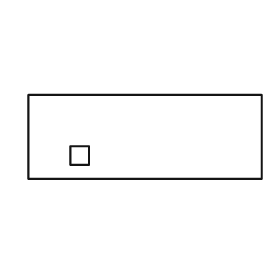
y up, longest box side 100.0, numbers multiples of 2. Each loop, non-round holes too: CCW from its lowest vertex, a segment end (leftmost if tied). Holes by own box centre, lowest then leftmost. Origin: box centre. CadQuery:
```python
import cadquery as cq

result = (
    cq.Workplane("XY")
    .moveTo(-50.0, -18.0)
    .lineTo(50.0, -18.0)
    .lineTo(50.0, 18.0)
    .lineTo(-50.0, 18.0)
    .close()
    .moveTo(-32.0, -12.0)
    .lineTo(-24.0, -12.0)
    .lineTo(-24.0, -4.0)
    .lineTo(-32.0, -4.0)
    .close()
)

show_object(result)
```